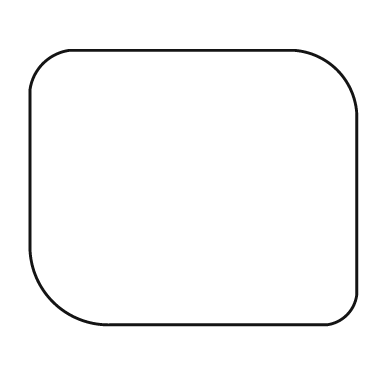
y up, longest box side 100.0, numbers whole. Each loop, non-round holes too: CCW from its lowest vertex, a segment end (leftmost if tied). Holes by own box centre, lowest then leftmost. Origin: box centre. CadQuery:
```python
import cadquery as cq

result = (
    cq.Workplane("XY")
    .moveTo(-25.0, -42.0)
    .lineTo(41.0, -42.0)
    .threePointArc((47.0, -39.0), (50.0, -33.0))
    .lineTo(50.0, 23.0)
    .threePointArc((44.0, 36.0), (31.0, 42.0))
    .lineTo(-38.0, 42.0)
    .threePointArc((-46.0, 38.0), (-50.0, 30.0))
    .lineTo(-50.0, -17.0)
    .threePointArc((-43.0, -35.0), (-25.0, -42.0))
    .close()
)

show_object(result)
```